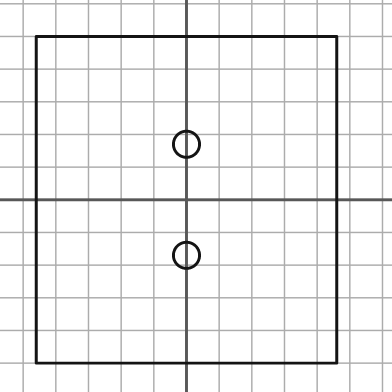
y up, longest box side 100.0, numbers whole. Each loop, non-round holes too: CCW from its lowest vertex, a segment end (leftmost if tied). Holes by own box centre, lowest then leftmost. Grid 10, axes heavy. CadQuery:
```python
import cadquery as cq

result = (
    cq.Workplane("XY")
    .moveTo(-46.0, -50.0)
    .lineTo(46.0, -50.0)
    .lineTo(46.0, 50.0)
    .lineTo(-46.0, 50.0)
    .close()
    .moveTo(0.0, -17.0)
    .circle(4.0)
    .moveTo(0.0, 17.0)
    .circle(4.0)
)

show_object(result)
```